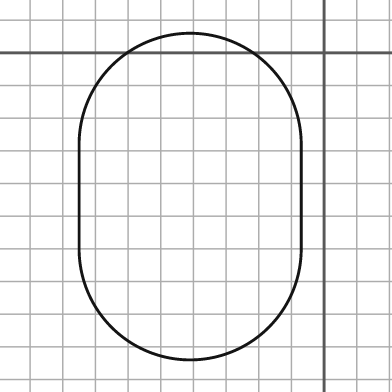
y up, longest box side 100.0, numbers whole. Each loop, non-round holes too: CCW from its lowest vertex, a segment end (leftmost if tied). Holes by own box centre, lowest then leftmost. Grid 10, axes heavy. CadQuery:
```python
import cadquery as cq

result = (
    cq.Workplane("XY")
    .moveTo(-75.0, -60.0)
    .threePointArc((-41.0, -94.0), (-7.0, -60.0))
    .lineTo(-7.0, -28.0)
    .threePointArc((-41.0, 6.0), (-75.0, -28.0))
    .close()
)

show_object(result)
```